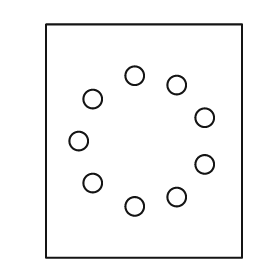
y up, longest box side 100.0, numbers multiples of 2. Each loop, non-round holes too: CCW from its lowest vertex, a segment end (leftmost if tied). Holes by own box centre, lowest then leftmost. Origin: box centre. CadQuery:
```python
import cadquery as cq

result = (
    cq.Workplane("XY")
    .moveTo(-42.0, -50.0)
    .lineTo(42.0, -50.0)
    .lineTo(42.0, 50.0)
    .lineTo(-42.0, 50.0)
    .close()
    .moveTo(-4.0, -28.0)
    .circle(4.0)
    .moveTo(14.0, -24.0)
    .circle(4.0)
    .moveTo(-22.0, -18.0)
    .circle(4.0)
    .moveTo(26.0, -10.0)
    .circle(4.0)
    .moveTo(-28.0, 0.0)
    .circle(4.0)
    .moveTo(26.0, 10.0)
    .circle(4.0)
    .moveTo(-22.0, 18.0)
    .circle(4.0)
    .moveTo(14.0, 24.0)
    .circle(4.0)
    .moveTo(-4.0, 28.0)
    .circle(4.0)
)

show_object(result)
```